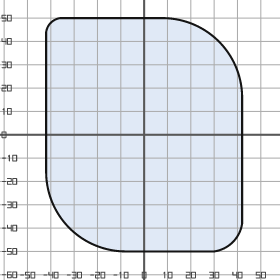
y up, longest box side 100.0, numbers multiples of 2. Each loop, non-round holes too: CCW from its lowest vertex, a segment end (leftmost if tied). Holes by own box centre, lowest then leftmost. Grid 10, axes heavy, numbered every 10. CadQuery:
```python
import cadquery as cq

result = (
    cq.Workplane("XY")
    .moveTo(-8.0, -50.0)
    .lineTo(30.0, -50.0)
    .threePointArc((38.0, -46.0), (42.0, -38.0))
    .lineTo(42.0, 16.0)
    .threePointArc((32.0, 40.0), (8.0, 50.0))
    .lineTo(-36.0, 50.0)
    .threePointArc((-40.0, 48.0), (-42.0, 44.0))
    .lineTo(-42.0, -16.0)
    .threePointArc((-32.0, -40.0), (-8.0, -50.0))
    .close()
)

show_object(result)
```